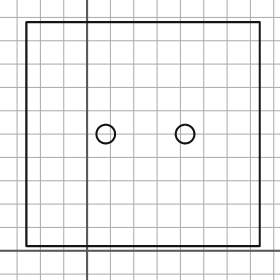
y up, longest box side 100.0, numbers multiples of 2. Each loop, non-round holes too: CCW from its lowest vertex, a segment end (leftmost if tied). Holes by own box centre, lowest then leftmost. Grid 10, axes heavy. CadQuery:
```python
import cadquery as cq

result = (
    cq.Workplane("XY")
    .moveTo(-26.0, 2.0)
    .lineTo(74.0, 2.0)
    .lineTo(74.0, 98.0)
    .lineTo(-26.0, 98.0)
    .close()
    .moveTo(8.0, 50.0)
    .circle(4.0)
    .moveTo(42.0, 50.0)
    .circle(4.0)
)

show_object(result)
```